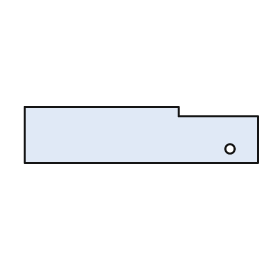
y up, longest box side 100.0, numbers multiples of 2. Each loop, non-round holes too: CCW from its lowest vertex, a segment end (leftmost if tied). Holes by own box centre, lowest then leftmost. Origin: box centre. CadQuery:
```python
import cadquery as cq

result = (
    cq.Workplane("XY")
    .moveTo(-50.0, -12.0)
    .lineTo(50.0, -12.0)
    .lineTo(50.0, 8.0)
    .lineTo(16.0, 8.0)
    .lineTo(16.0, 12.0)
    .lineTo(-50.0, 12.0)
    .close()
    .moveTo(38.0, -6.0)
    .circle(2.0)
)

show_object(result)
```